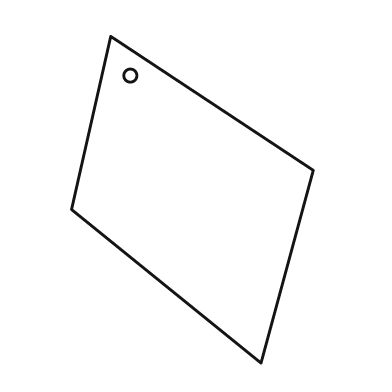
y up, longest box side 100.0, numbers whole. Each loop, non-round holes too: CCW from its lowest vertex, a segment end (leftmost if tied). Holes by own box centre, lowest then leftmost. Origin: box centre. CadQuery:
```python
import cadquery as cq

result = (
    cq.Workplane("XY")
    .moveTo(21.0, -50.0)
    .lineTo(37.0, 9.0)
    .lineTo(-25.0, 50.0)
    .lineTo(-37.0, -3.0)
    .close()
    .moveTo(-19.0, 38.0)
    .circle(2.0)
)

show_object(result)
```